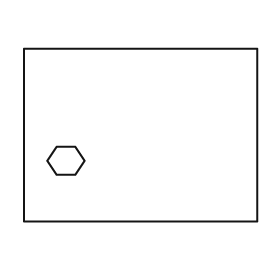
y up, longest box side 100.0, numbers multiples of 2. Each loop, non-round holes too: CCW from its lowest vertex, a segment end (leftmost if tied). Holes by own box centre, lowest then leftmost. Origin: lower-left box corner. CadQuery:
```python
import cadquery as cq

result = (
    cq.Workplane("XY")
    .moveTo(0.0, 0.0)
    .lineTo(100.0, 0.0)
    .lineTo(100.0, 74.0)
    .lineTo(0.0, 74.0)
    .close()
    .moveTo(14.0, 20.0)
    .lineTo(22.0, 20.0)
    .lineTo(26.0, 26.0)
    .lineTo(22.0, 32.0)
    .lineTo(14.0, 32.0)
    .lineTo(10.0, 26.0)
    .close()
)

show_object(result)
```